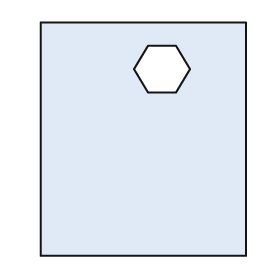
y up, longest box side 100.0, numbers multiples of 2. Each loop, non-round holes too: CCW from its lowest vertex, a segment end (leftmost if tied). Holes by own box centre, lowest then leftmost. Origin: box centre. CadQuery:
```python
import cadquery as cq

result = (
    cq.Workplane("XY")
    .moveTo(-44.0, -50.0)
    .lineTo(44.0, -50.0)
    .lineTo(44.0, 50.0)
    .lineTo(-44.0, 50.0)
    .close()
    .moveTo(2.0, 20.0)
    .lineTo(14.0, 20.0)
    .lineTo(20.0, 30.0)
    .lineTo(14.0, 40.0)
    .lineTo(2.0, 40.0)
    .lineTo(-4.0, 30.0)
    .close()
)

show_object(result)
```